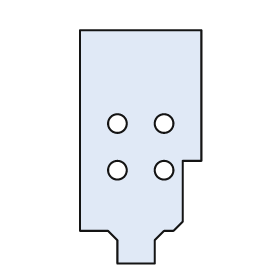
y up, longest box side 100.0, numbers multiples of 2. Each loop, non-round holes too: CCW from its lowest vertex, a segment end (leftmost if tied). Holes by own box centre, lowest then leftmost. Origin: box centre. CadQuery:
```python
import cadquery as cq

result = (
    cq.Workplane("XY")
    .moveTo(-10.0, -50.0)
    .lineTo(6.0, -50.0)
    .lineTo(6.0, -40.0)
    .lineTo(10.0, -36.0)
    .lineTo(14.0, -36.0)
    .lineTo(18.0, -32.0)
    .lineTo(18.0, -6.0)
    .lineTo(26.0, -6.0)
    .lineTo(26.0, 50.0)
    .lineTo(-26.0, 50.0)
    .lineTo(-26.0, -36.0)
    .lineTo(-14.0, -36.0)
    .lineTo(-10.0, -40.0)
    .close()
    .moveTo(-10.0, -10.0)
    .circle(4.0)
    .moveTo(10.0, -10.0)
    .circle(4.0)
    .moveTo(-10.0, 10.0)
    .circle(4.0)
    .moveTo(10.0, 10.0)
    .circle(4.0)
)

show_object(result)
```